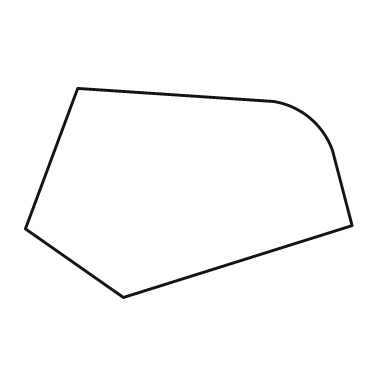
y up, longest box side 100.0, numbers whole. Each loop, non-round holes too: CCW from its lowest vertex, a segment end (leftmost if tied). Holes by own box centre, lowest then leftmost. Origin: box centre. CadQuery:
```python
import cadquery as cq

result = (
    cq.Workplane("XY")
    .moveTo(-20.0, -32.0)
    .lineTo(50.0, -10.0)
    .lineTo(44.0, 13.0)
    .threePointArc((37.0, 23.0), (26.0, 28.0))
    .lineTo(-34.0, 32.0)
    .lineTo(-50.0, -11.0)
    .close()
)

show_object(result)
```